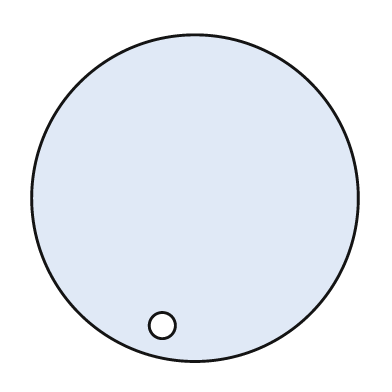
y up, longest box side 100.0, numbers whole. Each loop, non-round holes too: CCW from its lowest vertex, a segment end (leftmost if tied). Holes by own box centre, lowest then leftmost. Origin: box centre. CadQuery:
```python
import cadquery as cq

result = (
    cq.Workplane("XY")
    .moveTo(0.0, 0.0)
    .circle(50.0)
    .moveTo(-10.0, -39.0)
    .circle(4.0)
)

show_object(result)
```